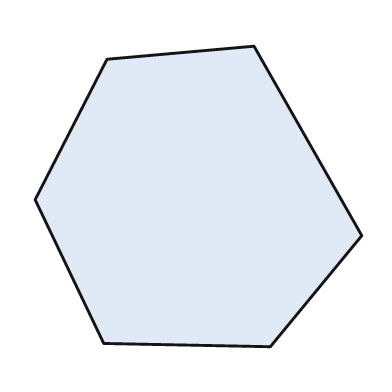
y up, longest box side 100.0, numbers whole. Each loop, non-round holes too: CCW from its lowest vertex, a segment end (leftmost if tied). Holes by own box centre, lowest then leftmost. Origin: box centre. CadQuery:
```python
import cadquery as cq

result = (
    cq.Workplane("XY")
    .moveTo(22.0, -46.0)
    .lineTo(50.0, -12.0)
    .lineTo(17.0, 46.0)
    .lineTo(-28.0, 42.0)
    .lineTo(-50.0, -1.0)
    .lineTo(-29.0, -45.0)
    .close()
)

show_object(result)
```